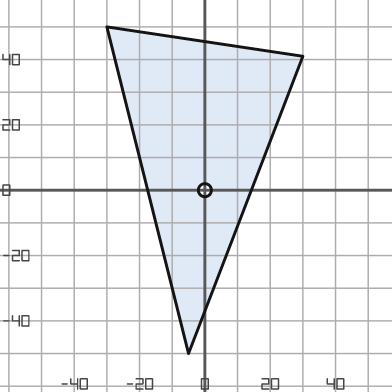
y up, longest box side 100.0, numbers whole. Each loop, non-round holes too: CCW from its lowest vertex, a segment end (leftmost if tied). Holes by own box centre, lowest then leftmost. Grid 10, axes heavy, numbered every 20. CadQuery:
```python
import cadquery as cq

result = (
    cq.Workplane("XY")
    .moveTo(-5.0, -50.0)
    .lineTo(30.0, 41.0)
    .lineTo(-30.0, 50.0)
    .close()
    .moveTo(0.0, 0.0)
    .circle(2.0)
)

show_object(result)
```